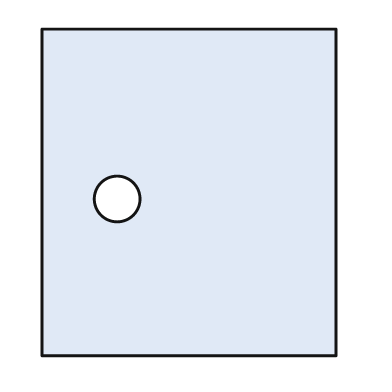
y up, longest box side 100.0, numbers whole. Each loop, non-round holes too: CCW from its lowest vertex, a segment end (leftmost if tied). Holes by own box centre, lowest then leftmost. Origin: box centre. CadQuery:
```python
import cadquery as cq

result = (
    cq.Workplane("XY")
    .moveTo(-45.0, -50.0)
    .lineTo(45.0, -50.0)
    .lineTo(45.0, 50.0)
    .lineTo(-45.0, 50.0)
    .close()
    .moveTo(-22.0, -2.0)
    .circle(7.0)
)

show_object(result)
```